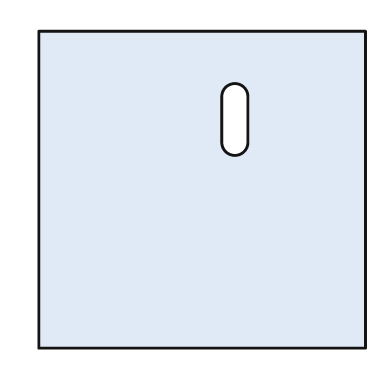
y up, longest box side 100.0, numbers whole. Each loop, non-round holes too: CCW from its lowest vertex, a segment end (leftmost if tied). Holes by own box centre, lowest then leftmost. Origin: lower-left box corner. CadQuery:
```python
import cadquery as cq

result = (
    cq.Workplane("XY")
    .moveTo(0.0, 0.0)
    .lineTo(100.0, 0.0)
    .lineTo(100.0, 97.0)
    .lineTo(0.0, 97.0)
    .close()
    .moveTo(56.0, 63.0)
    .threePointArc((60.0, 59.0), (64.0, 63.0))
    .lineTo(64.0, 77.0)
    .threePointArc((60.0, 81.0), (56.0, 77.0))
    .close()
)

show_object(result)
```